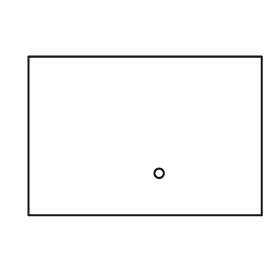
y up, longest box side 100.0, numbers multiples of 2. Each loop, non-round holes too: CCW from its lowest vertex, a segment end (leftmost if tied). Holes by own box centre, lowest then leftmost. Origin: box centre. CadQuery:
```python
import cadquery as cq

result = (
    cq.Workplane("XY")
    .moveTo(-50.0, -34.0)
    .lineTo(50.0, -34.0)
    .lineTo(50.0, 34.0)
    .lineTo(-50.0, 34.0)
    .close()
    .moveTo(6.0, -16.0)
    .circle(2.0)
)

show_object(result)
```